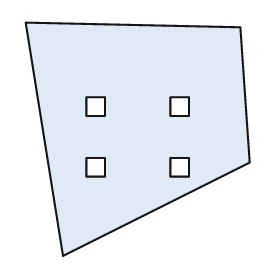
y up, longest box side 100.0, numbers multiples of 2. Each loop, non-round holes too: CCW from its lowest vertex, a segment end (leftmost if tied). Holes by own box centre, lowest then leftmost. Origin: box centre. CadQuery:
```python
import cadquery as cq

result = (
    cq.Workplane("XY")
    .moveTo(-32.0, -50.0)
    .lineTo(48.0, -10.0)
    .lineTo(44.0, 48.0)
    .lineTo(-48.0, 50.0)
    .close()
    .moveTo(-22.0, -16.0)
    .lineTo(-14.0, -16.0)
    .lineTo(-14.0, -8.0)
    .lineTo(-22.0, -8.0)
    .close()
    .moveTo(14.0, -16.0)
    .lineTo(22.0, -16.0)
    .lineTo(22.0, -8.0)
    .lineTo(14.0, -8.0)
    .close()
    .moveTo(-22.0, 10.0)
    .lineTo(-14.0, 10.0)
    .lineTo(-14.0, 18.0)
    .lineTo(-22.0, 18.0)
    .close()
    .moveTo(14.0, 10.0)
    .lineTo(22.0, 10.0)
    .lineTo(22.0, 18.0)
    .lineTo(14.0, 18.0)
    .close()
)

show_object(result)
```